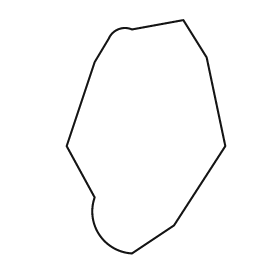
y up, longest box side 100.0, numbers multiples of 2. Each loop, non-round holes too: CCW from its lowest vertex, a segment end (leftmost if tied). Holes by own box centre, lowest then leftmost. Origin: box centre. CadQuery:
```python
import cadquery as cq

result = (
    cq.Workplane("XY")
    .moveTo(-6.0, -50.0)
    .lineTo(12.0, -38.0)
    .lineTo(34.0, -4.0)
    .lineTo(26.0, 34.0)
    .lineTo(16.0, 50.0)
    .lineTo(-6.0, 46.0)
    .threePointArc((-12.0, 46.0), (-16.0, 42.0))
    .lineTo(-22.0, 32.0)
    .lineTo(-34.0, -4.0)
    .lineTo(-22.0, -26.0)
    .threePointArc((-20.0, -42.0), (-6.0, -50.0))
    .close()
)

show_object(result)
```